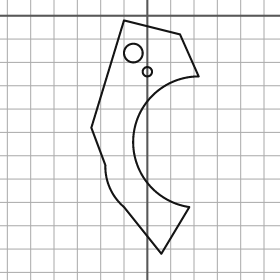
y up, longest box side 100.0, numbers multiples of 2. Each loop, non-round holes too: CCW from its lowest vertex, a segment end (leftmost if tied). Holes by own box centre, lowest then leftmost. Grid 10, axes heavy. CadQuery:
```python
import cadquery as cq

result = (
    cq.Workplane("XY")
    .moveTo(6.0, -102.0)
    .lineTo(18.0, -82.0)
    .threePointArc((-6.0, -52.0), (22.0, -26.0))
    .lineTo(14.0, -8.0)
    .lineTo(-10.0, -2.0)
    .lineTo(-24.0, -48.0)
    .lineTo(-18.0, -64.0)
    .threePointArc((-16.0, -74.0), (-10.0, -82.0))
    .close()
    .moveTo(0.0, -24.0)
    .circle(2.0)
    .moveTo(-6.0, -16.0)
    .circle(4.0)
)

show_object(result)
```